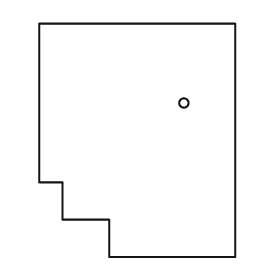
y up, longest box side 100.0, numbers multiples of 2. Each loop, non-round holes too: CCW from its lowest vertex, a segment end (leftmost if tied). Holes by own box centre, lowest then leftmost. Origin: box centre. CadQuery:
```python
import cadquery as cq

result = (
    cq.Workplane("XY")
    .moveTo(-12.0, -50.0)
    .lineTo(42.0, -50.0)
    .lineTo(42.0, 50.0)
    .lineTo(-42.0, 50.0)
    .lineTo(-42.0, -18.0)
    .lineTo(-32.0, -18.0)
    .lineTo(-32.0, -34.0)
    .lineTo(-12.0, -34.0)
    .close()
    .moveTo(20.0, 16.0)
    .circle(2.0)
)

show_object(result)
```